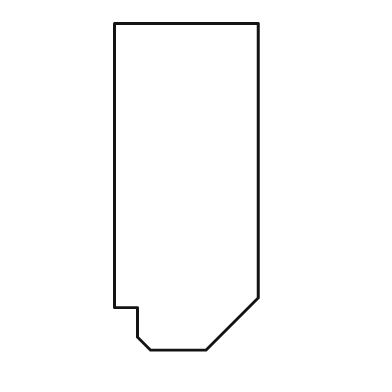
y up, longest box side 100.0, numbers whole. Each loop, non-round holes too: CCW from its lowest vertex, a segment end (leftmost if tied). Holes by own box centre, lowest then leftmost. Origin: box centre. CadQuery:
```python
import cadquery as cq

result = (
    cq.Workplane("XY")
    .moveTo(-11.0, -50.0)
    .lineTo(6.0, -50.0)
    .lineTo(22.0, -34.0)
    .lineTo(22.0, 50.0)
    .lineTo(-22.0, 50.0)
    .lineTo(-22.0, -37.0)
    .lineTo(-15.0, -37.0)
    .lineTo(-15.0, -46.0)
    .close()
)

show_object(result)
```